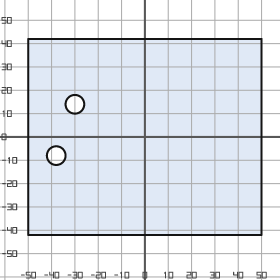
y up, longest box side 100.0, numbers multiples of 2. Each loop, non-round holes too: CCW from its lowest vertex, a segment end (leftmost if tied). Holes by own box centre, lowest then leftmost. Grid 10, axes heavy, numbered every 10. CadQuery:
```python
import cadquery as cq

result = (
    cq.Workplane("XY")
    .moveTo(-50.0, -42.0)
    .lineTo(50.0, -42.0)
    .lineTo(50.0, 42.0)
    .lineTo(-50.0, 42.0)
    .close()
    .moveTo(-38.0, -8.0)
    .circle(4.0)
    .moveTo(-30.0, 14.0)
    .circle(4.0)
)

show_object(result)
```